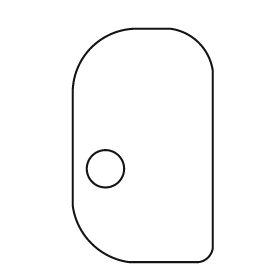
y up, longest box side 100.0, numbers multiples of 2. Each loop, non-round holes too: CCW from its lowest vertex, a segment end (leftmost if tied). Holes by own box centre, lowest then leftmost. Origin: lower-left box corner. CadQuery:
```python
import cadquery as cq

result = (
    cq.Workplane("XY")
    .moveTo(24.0, 0.0)
    .lineTo(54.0, 0.0)
    .threePointArc((58.0, 2.0), (60.0, 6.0))
    .lineTo(60.0, 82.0)
    .threePointArc((54.0, 94.0), (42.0, 100.0))
    .lineTo(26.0, 100.0)
    .threePointArc((8.0, 92.0), (0.0, 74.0))
    .lineTo(0.0, 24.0)
    .threePointArc((8.0, 8.0), (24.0, 0.0))
    .close()
    .moveTo(14.0, 40.0)
    .circle(8.0)
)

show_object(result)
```